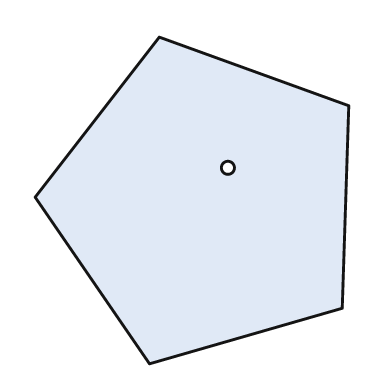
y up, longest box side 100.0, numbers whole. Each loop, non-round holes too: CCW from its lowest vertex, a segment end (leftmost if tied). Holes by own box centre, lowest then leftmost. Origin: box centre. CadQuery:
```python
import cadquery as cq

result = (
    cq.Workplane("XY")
    .moveTo(-13.0, -50.0)
    .lineTo(46.0, -33.0)
    .lineTo(48.0, 29.0)
    .lineTo(-10.0, 50.0)
    .lineTo(-48.0, 1.0)
    .close()
    .moveTo(11.0, 10.0)
    .circle(2.0)
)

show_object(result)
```